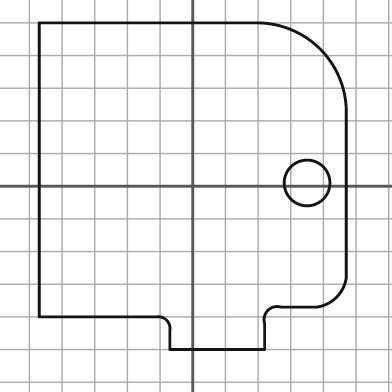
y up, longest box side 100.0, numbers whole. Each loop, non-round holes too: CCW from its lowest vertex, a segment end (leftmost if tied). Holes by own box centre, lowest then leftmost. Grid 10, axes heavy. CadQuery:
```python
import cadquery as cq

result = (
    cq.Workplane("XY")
    .moveTo(-7.0, -50.0)
    .lineTo(22.0, -50.0)
    .lineTo(22.0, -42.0)
    .threePointArc((23.0, -38.0), (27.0, -37.0))
    .lineTo(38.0, -37.0)
    .threePointArc((44.0, -34.0), (47.0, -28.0))
    .lineTo(47.0, 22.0)
    .threePointArc((39.0, 42.0), (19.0, 50.0))
    .lineTo(-47.0, 50.0)
    .lineTo(-47.0, -40.0)
    .lineTo(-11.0, -40.0)
    .threePointArc((-8.0, -41.0), (-7.0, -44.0))
    .close()
    .moveTo(35.0, 1.0)
    .circle(7.0)
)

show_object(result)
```